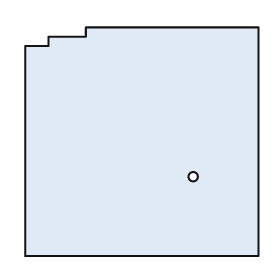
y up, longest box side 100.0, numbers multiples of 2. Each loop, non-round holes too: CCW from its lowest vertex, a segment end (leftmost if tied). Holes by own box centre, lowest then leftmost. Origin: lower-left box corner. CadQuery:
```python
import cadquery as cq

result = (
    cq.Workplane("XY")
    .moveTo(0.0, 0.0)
    .lineTo(100.0, 0.0)
    .lineTo(100.0, 98.0)
    .lineTo(26.0, 98.0)
    .lineTo(26.0, 94.0)
    .lineTo(10.0, 94.0)
    .lineTo(10.0, 90.0)
    .lineTo(0.0, 90.0)
    .close()
    .moveTo(72.0, 34.0)
    .circle(2.0)
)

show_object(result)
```